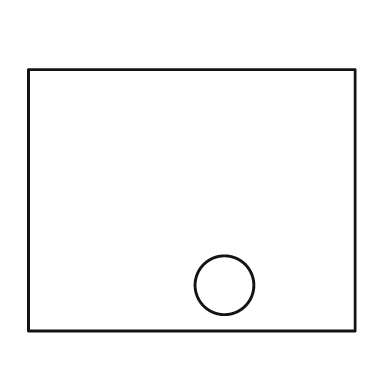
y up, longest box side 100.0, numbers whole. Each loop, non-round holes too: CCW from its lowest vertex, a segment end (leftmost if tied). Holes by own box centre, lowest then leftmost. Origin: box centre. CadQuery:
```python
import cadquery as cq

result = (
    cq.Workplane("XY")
    .moveTo(-50.0, -40.0)
    .lineTo(50.0, -40.0)
    .lineTo(50.0, 40.0)
    .lineTo(-50.0, 40.0)
    .close()
    .moveTo(10.0, -26.0)
    .circle(9.0)
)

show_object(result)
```